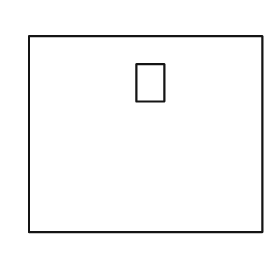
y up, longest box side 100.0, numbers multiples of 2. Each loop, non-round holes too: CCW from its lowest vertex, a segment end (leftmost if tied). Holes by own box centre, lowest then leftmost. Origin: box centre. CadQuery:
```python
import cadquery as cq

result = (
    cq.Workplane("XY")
    .moveTo(-50.0, -42.0)
    .lineTo(50.0, -42.0)
    .lineTo(50.0, 42.0)
    .lineTo(-50.0, 42.0)
    .close()
    .moveTo(-4.0, 14.0)
    .lineTo(8.0, 14.0)
    .lineTo(8.0, 30.0)
    .lineTo(-4.0, 30.0)
    .close()
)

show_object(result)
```